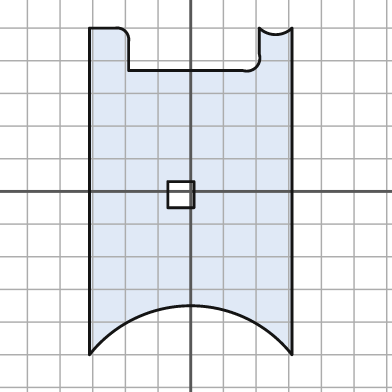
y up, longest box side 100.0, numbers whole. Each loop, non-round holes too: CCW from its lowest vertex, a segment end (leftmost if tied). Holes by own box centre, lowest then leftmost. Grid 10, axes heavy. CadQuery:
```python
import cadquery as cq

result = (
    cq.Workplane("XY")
    .moveTo(-31.0, -50.0)
    .threePointArc((0.0, -35.0), (31.0, -50.0))
    .lineTo(31.0, 50.0)
    .threePointArc((26.0, 48.0), (21.0, 50.0))
    .lineTo(21.0, 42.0)
    .threePointArc((20.0, 38.0), (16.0, 37.0))
    .lineTo(-19.0, 37.0)
    .lineTo(-19.0, 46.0)
    .threePointArc((-20.0, 49.0), (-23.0, 50.0))
    .lineTo(-31.0, 50.0)
    .close()
    .moveTo(-7.0, -5.0)
    .lineTo(1.0, -5.0)
    .lineTo(1.0, 3.0)
    .lineTo(-7.0, 3.0)
    .close()
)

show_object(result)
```